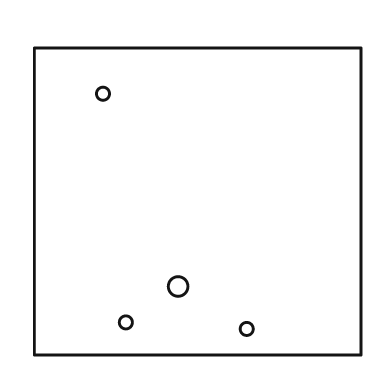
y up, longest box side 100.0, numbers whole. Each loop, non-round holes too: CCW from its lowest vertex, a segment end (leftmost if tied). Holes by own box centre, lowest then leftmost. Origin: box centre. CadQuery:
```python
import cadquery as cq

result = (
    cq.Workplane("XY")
    .moveTo(-50.0, -47.0)
    .lineTo(50.0, -47.0)
    .lineTo(50.0, 47.0)
    .lineTo(-50.0, 47.0)
    .close()
    .moveTo(15.0, -39.0)
    .circle(2.0)
    .moveTo(-22.0, -37.0)
    .circle(2.0)
    .moveTo(-6.0, -26.0)
    .circle(3.0)
    .moveTo(-29.0, 33.0)
    .circle(2.0)
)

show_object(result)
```